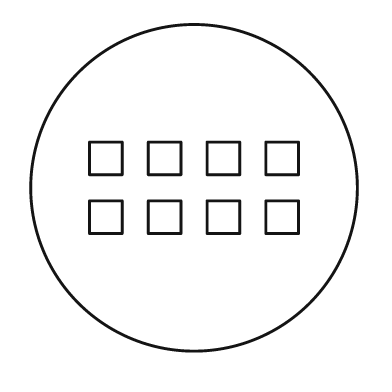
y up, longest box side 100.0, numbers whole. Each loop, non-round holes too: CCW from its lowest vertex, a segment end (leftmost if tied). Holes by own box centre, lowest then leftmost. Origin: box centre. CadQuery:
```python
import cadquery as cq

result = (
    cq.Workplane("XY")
    .moveTo(0.0, 0.0)
    .circle(50.0)
    .moveTo(-32.0, -14.0)
    .lineTo(-22.0, -14.0)
    .lineTo(-22.0, -4.0)
    .lineTo(-32.0, -4.0)
    .close()
    .moveTo(-14.0, -14.0)
    .lineTo(-4.0, -14.0)
    .lineTo(-4.0, -4.0)
    .lineTo(-14.0, -4.0)
    .close()
    .moveTo(4.0, -14.0)
    .lineTo(14.0, -14.0)
    .lineTo(14.0, -4.0)
    .lineTo(4.0, -4.0)
    .close()
    .moveTo(22.0, -14.0)
    .lineTo(32.0, -14.0)
    .lineTo(32.0, -4.0)
    .lineTo(22.0, -4.0)
    .close()
    .moveTo(-32.0, 4.0)
    .lineTo(-22.0, 4.0)
    .lineTo(-22.0, 14.0)
    .lineTo(-32.0, 14.0)
    .close()
    .moveTo(-14.0, 4.0)
    .lineTo(-4.0, 4.0)
    .lineTo(-4.0, 14.0)
    .lineTo(-14.0, 14.0)
    .close()
    .moveTo(4.0, 4.0)
    .lineTo(14.0, 4.0)
    .lineTo(14.0, 14.0)
    .lineTo(4.0, 14.0)
    .close()
    .moveTo(22.0, 4.0)
    .lineTo(32.0, 4.0)
    .lineTo(32.0, 14.0)
    .lineTo(22.0, 14.0)
    .close()
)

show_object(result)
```